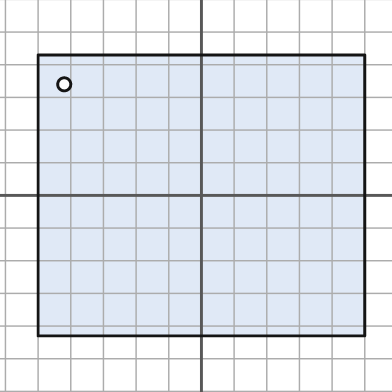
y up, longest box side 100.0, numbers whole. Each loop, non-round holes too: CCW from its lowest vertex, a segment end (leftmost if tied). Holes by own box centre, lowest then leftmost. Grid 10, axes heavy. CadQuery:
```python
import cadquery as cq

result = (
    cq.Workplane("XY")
    .moveTo(-50.0, -43.0)
    .lineTo(50.0, -43.0)
    .lineTo(50.0, 43.0)
    .lineTo(-50.0, 43.0)
    .close()
    .moveTo(-42.0, 34.0)
    .circle(2.0)
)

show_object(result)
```